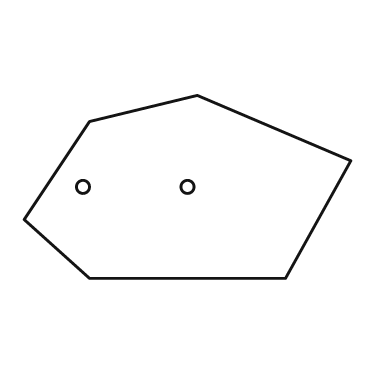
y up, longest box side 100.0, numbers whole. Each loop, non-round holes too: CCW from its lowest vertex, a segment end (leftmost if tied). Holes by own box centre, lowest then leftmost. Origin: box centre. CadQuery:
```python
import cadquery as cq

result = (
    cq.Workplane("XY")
    .moveTo(-30.0, -28.0)
    .lineTo(30.0, -28.0)
    .lineTo(50.0, 8.0)
    .lineTo(3.0, 28.0)
    .lineTo(-30.0, 20.0)
    .lineTo(-50.0, -10.0)
    .close()
    .moveTo(-32.0, 0.0)
    .circle(2.0)
    .moveTo(0.0, 0.0)
    .circle(2.0)
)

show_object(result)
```